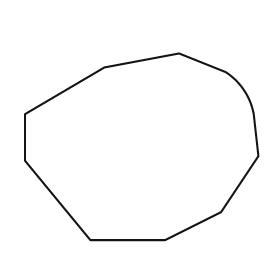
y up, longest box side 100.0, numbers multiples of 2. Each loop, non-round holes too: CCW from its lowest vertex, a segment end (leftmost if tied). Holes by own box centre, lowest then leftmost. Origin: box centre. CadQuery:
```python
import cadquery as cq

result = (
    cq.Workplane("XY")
    .moveTo(-22.0, -40.0)
    .lineTo(10.0, -40.0)
    .lineTo(34.0, -28.0)
    .lineTo(50.0, -4.0)
    .lineTo(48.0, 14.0)
    .threePointArc((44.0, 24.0), (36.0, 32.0))
    .lineTo(16.0, 40.0)
    .lineTo(-16.0, 34.0)
    .lineTo(-50.0, 14.0)
    .lineTo(-50.0, -6.0)
    .close()
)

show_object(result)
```